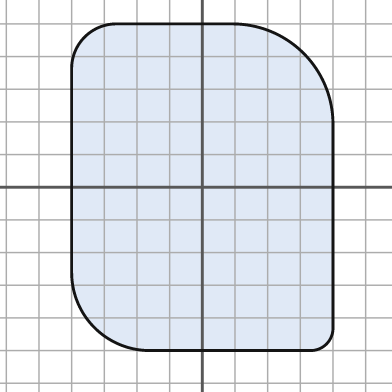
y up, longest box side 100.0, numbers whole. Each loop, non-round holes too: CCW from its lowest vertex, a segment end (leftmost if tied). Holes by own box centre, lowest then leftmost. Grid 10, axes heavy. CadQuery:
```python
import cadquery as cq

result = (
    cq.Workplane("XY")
    .moveTo(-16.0, -50.0)
    .lineTo(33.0, -50.0)
    .threePointArc((38.0, -48.0), (40.0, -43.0))
    .lineTo(40.0, 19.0)
    .threePointArc((31.0, 41.0), (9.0, 50.0))
    .lineTo(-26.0, 50.0)
    .threePointArc((-36.0, 46.0), (-40.0, 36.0))
    .lineTo(-40.0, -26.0)
    .threePointArc((-33.0, -43.0), (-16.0, -50.0))
    .close()
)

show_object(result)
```